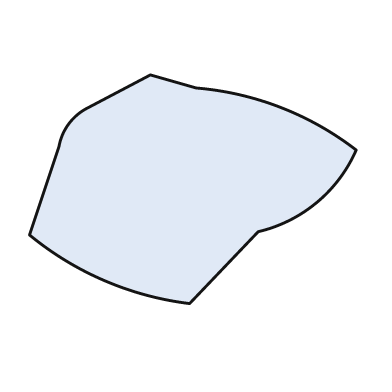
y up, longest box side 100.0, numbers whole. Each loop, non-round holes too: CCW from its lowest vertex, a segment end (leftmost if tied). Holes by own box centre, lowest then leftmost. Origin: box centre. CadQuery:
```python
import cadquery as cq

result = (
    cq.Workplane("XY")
    .moveTo(-1.0, -35.0)
    .lineTo(20.0, -13.0)
    .threePointArc((38.0, -4.0), (50.0, 12.0))
    .threePointArc((27.0, 25.0), (1.0, 31.0))
    .lineTo(-13.0, 35.0)
    .lineTo(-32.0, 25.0)
    .threePointArc((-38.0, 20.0), (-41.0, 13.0))
    .lineTo(-50.0, -14.0)
    .threePointArc((-27.0, -28.0), (-1.0, -35.0))
    .close()
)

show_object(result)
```